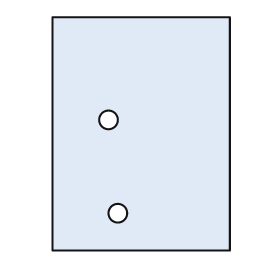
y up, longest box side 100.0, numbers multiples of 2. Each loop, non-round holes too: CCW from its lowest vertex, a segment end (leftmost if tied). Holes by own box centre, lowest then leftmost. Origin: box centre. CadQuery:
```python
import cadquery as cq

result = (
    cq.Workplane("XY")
    .moveTo(-38.0, -50.0)
    .lineTo(38.0, -50.0)
    .lineTo(38.0, 50.0)
    .lineTo(-38.0, 50.0)
    .close()
    .moveTo(-10.0, -34.0)
    .circle(4.0)
    .moveTo(-14.0, 6.0)
    .circle(4.0)
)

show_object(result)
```